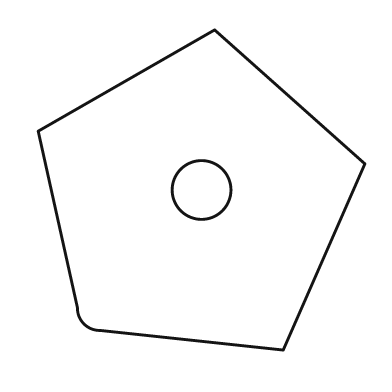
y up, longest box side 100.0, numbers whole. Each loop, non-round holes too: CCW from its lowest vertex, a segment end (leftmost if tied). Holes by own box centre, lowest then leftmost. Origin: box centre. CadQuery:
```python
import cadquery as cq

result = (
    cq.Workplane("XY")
    .moveTo(25.0, -49.0)
    .lineTo(50.0, 8.0)
    .lineTo(4.0, 49.0)
    .lineTo(-50.0, 18.0)
    .lineTo(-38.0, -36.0)
    .threePointArc((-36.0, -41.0), (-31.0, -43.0))
    .close()
    .moveTo(0.0, 0.0)
    .circle(9.0)
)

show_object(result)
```